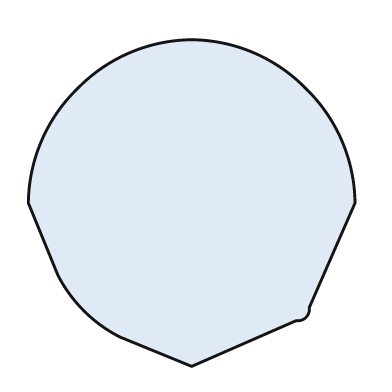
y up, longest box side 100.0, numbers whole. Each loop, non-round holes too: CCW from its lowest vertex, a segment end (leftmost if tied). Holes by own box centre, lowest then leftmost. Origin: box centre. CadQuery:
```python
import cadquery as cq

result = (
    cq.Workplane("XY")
    .moveTo(0.0, -50.0)
    .lineTo(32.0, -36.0)
    .threePointArc((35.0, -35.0), (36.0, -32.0))
    .lineTo(50.0, 0.0)
    .threePointArc((46.0, 19.0), (35.0, 35.0))
    .threePointArc((19.0, 46.0), (0.0, 50.0))
    .threePointArc((-19.0, 46.0), (-35.0, 35.0))
    .threePointArc((-46.0, 19.0), (-50.0, 0.0))
    .lineTo(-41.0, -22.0)
    .threePointArc((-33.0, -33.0), (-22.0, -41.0))
    .close()
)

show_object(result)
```